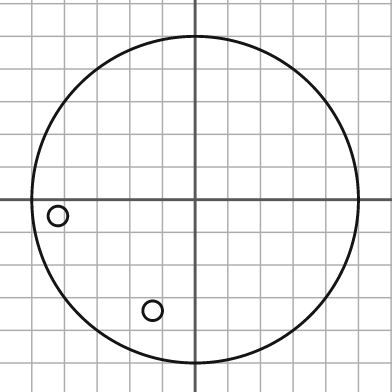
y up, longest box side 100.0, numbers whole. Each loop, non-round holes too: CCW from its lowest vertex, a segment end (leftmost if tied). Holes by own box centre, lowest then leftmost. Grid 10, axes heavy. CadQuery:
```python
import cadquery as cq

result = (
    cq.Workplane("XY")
    .moveTo(0.0, 0.0)
    .circle(50.0)
    .moveTo(-13.0, -34.0)
    .circle(3.0)
    .moveTo(-42.0, -5.0)
    .circle(3.0)
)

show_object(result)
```